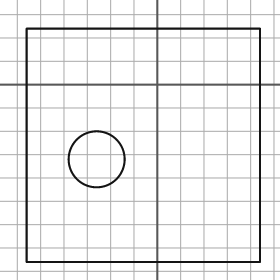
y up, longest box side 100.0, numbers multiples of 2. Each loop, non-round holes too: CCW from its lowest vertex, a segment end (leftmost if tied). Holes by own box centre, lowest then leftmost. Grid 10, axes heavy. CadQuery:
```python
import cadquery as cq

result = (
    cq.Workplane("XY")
    .moveTo(-56.0, -76.0)
    .lineTo(44.0, -76.0)
    .lineTo(44.0, 24.0)
    .lineTo(-56.0, 24.0)
    .close()
    .moveTo(-26.0, -32.0)
    .circle(12.0)
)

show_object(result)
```